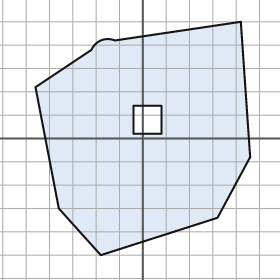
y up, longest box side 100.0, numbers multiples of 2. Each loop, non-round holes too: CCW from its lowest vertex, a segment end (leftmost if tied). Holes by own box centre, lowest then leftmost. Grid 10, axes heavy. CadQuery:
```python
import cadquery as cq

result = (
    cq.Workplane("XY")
    .moveTo(-18.0, -50.0)
    .lineTo(32.0, -34.0)
    .lineTo(46.0, -8.0)
    .lineTo(42.0, 50.0)
    .lineTo(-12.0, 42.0)
    .threePointArc((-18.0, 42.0), (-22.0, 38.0))
    .lineTo(-46.0, 22.0)
    .lineTo(-36.0, -30.0)
    .close()
    .moveTo(-4.0, 2.0)
    .lineTo(8.0, 2.0)
    .lineTo(8.0, 14.0)
    .lineTo(-4.0, 14.0)
    .close()
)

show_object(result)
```